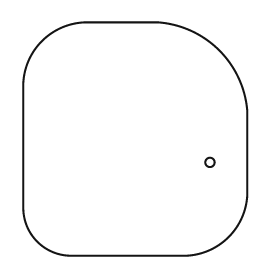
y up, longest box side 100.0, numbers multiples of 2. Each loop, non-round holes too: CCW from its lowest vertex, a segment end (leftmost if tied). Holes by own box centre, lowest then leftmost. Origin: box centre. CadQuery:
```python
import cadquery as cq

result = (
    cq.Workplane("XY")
    .moveTo(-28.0, -50.0)
    .lineTo(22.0, -50.0)
    .threePointArc((40.0, -42.0), (48.0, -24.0))
    .lineTo(48.0, 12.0)
    .threePointArc((36.0, 38.0), (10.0, 50.0))
    .lineTo(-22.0, 50.0)
    .threePointArc((-40.0, 42.0), (-48.0, 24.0))
    .lineTo(-48.0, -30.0)
    .threePointArc((-42.0, -44.0), (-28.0, -50.0))
    .close()
    .moveTo(32.0, -10.0)
    .circle(2.0)
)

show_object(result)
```